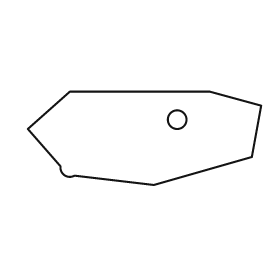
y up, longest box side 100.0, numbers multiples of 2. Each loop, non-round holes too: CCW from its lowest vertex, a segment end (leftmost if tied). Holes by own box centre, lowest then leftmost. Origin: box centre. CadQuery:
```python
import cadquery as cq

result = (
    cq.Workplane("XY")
    .moveTo(4.0, -20.0)
    .lineTo(46.0, -8.0)
    .lineTo(50.0, 14.0)
    .lineTo(28.0, 20.0)
    .lineTo(-32.0, 20.0)
    .lineTo(-50.0, 4.0)
    .lineTo(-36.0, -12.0)
    .threePointArc((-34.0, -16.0), (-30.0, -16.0))
    .close()
    .moveTo(14.0, 8.0)
    .circle(4.0)
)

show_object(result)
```